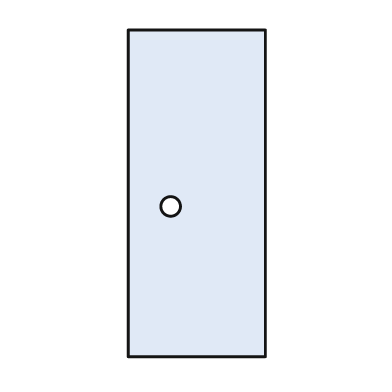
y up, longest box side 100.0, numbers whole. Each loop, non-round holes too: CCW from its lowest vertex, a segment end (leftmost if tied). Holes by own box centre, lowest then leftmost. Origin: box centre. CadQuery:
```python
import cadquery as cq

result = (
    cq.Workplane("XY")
    .moveTo(-21.0, -50.0)
    .lineTo(21.0, -50.0)
    .lineTo(21.0, 50.0)
    .lineTo(-21.0, 50.0)
    .close()
    .moveTo(-8.0, -4.0)
    .circle(3.0)
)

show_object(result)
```